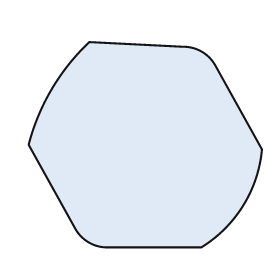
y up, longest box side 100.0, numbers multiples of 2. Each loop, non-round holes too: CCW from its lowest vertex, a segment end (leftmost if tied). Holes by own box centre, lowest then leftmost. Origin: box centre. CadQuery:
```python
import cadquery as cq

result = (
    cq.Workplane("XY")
    .moveTo(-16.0, -44.0)
    .lineTo(24.0, -44.0)
    .threePointArc((42.0, -26.0), (50.0, -2.0))
    .lineTo(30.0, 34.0)
    .threePointArc((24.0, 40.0), (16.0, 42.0))
    .lineTo(-24.0, 44.0)
    .threePointArc((-40.0, 24.0), (-50.0, 0.0))
    .lineTo(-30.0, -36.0)
    .threePointArc((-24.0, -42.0), (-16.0, -44.0))
    .close()
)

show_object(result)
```